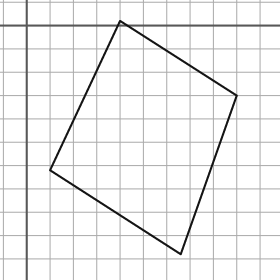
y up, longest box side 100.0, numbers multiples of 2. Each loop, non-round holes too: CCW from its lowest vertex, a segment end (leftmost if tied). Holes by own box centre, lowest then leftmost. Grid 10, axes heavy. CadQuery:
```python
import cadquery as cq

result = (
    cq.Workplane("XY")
    .moveTo(66.0, -98.0)
    .lineTo(90.0, -30.0)
    .lineTo(40.0, 2.0)
    .lineTo(10.0, -62.0)
    .close()
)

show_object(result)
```